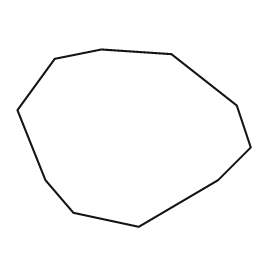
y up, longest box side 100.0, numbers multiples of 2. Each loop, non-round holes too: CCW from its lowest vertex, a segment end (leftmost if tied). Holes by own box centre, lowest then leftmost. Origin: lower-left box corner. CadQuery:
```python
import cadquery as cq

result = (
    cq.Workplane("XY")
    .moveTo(52.0, 0.0)
    .lineTo(86.0, 20.0)
    .lineTo(100.0, 34.0)
    .lineTo(94.0, 52.0)
    .lineTo(66.0, 74.0)
    .lineTo(36.0, 76.0)
    .lineTo(16.0, 72.0)
    .lineTo(0.0, 50.0)
    .lineTo(12.0, 20.0)
    .lineTo(24.0, 6.0)
    .close()
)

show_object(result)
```